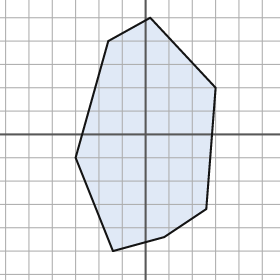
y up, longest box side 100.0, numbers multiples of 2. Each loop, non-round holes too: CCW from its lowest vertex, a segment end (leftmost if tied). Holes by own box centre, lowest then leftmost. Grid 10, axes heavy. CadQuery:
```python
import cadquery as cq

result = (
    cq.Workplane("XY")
    .moveTo(-14.0, -50.0)
    .lineTo(8.0, -44.0)
    .lineTo(26.0, -32.0)
    .lineTo(30.0, 20.0)
    .lineTo(2.0, 50.0)
    .lineTo(-16.0, 40.0)
    .lineTo(-30.0, -10.0)
    .close()
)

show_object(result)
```